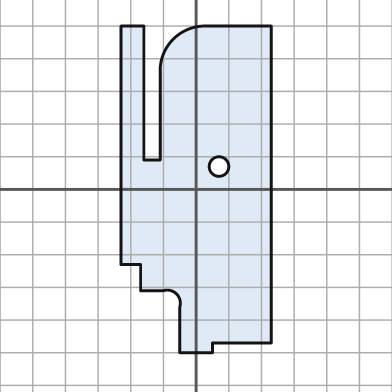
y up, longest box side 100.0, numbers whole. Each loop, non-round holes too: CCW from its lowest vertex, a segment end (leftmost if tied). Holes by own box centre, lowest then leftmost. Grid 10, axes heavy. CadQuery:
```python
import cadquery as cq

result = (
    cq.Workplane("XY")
    .moveTo(-5.0, -50.0)
    .lineTo(5.0, -50.0)
    .lineTo(5.0, -47.0)
    .lineTo(23.0, -47.0)
    .lineTo(23.0, 50.0)
    .lineTo(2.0, 50.0)
    .threePointArc((-7.0, 46.0), (-11.0, 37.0))
    .lineTo(-11.0, 9.0)
    .lineTo(-16.0, 9.0)
    .lineTo(-16.0, 50.0)
    .lineTo(-23.0, 50.0)
    .lineTo(-23.0, -23.0)
    .lineTo(-17.0, -23.0)
    .lineTo(-17.0, -31.0)
    .lineTo(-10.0, -31.0)
    .threePointArc((-6.0, -32.0), (-5.0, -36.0))
    .close()
    .moveTo(7.0, 7.0)
    .circle(3.0)
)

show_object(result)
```